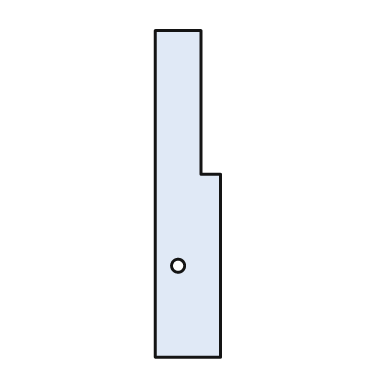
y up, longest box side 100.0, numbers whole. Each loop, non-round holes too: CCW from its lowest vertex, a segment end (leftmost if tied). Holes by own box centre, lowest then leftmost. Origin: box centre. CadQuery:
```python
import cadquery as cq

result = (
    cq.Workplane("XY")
    .moveTo(-10.0, -50.0)
    .lineTo(10.0, -50.0)
    .lineTo(10.0, 6.0)
    .lineTo(4.0, 6.0)
    .lineTo(4.0, 50.0)
    .lineTo(-10.0, 50.0)
    .close()
    .moveTo(-3.0, -22.0)
    .circle(2.0)
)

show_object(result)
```